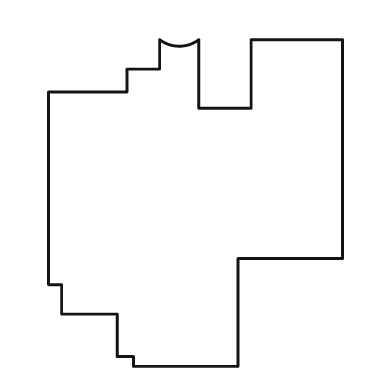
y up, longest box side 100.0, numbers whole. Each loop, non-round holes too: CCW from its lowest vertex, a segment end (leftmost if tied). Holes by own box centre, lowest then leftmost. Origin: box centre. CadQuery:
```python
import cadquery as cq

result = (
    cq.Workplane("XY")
    .moveTo(-19.0, -50.0)
    .lineTo(13.0, -50.0)
    .lineTo(13.0, -17.0)
    .lineTo(45.0, -17.0)
    .lineTo(45.0, 50.0)
    .lineTo(17.0, 50.0)
    .lineTo(17.0, 29.0)
    .lineTo(1.0, 29.0)
    .lineTo(1.0, 50.0)
    .threePointArc((-5.0, 48.0), (-11.0, 50.0))
    .lineTo(-11.0, 41.0)
    .lineTo(-21.0, 41.0)
    .lineTo(-21.0, 34.0)
    .lineTo(-45.0, 34.0)
    .lineTo(-45.0, -25.0)
    .lineTo(-41.0, -25.0)
    .lineTo(-41.0, -34.0)
    .lineTo(-24.0, -34.0)
    .lineTo(-24.0, -47.0)
    .lineTo(-19.0, -47.0)
    .close()
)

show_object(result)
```